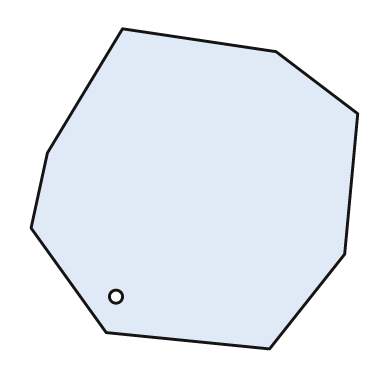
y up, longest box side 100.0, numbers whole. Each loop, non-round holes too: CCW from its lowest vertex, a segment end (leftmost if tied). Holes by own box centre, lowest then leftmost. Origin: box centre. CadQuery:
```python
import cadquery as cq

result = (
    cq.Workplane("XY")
    .moveTo(23.0, -49.0)
    .lineTo(46.0, -20.0)
    .lineTo(50.0, 23.0)
    .lineTo(25.0, 42.0)
    .lineTo(-22.0, 49.0)
    .lineTo(-45.0, 11.0)
    .lineTo(-50.0, -12.0)
    .lineTo(-27.0, -44.0)
    .close()
    .moveTo(-24.0, -33.0)
    .circle(2.0)
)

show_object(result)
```